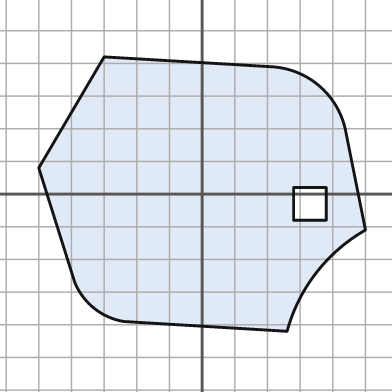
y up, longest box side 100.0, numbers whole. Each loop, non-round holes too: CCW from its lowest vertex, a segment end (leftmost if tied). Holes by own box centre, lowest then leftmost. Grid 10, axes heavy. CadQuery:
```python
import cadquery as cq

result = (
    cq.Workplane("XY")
    .moveTo(26.0, -42.0)
    .threePointArc((35.0, -24.0), (50.0, -11.0))
    .lineTo(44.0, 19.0)
    .threePointArc((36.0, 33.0), (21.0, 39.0))
    .lineTo(-30.0, 42.0)
    .lineTo(-50.0, 8.0)
    .lineTo(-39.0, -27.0)
    .threePointArc((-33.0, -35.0), (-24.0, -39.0))
    .close()
    .moveTo(28.0, -8.0)
    .lineTo(38.0, -8.0)
    .lineTo(38.0, 2.0)
    .lineTo(28.0, 2.0)
    .close()
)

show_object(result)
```